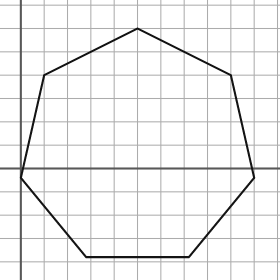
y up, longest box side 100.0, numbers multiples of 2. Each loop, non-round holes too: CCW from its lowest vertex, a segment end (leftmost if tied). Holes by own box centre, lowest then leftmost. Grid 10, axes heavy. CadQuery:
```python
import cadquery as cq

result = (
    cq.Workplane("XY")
    .moveTo(28.0, -38.0)
    .lineTo(72.0, -38.0)
    .lineTo(100.0, -4.0)
    .lineTo(90.0, 40.0)
    .lineTo(50.0, 60.0)
    .lineTo(10.0, 40.0)
    .lineTo(0.0, -4.0)
    .close()
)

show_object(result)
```